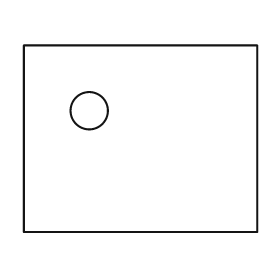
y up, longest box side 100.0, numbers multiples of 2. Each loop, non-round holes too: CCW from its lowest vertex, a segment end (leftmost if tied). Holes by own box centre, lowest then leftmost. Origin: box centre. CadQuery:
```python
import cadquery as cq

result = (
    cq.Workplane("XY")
    .moveTo(-50.0, -40.0)
    .lineTo(50.0, -40.0)
    .lineTo(50.0, 40.0)
    .lineTo(-50.0, 40.0)
    .close()
    .moveTo(-22.0, 12.0)
    .circle(8.0)
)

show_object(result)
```